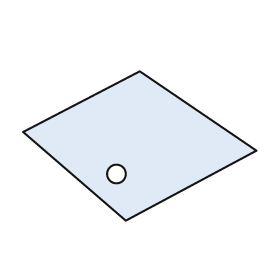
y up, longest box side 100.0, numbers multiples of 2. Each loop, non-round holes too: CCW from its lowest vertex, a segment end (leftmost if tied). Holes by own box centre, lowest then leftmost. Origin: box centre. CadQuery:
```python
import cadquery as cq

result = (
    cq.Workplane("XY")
    .moveTo(-6.0, -32.0)
    .lineTo(50.0, -2.0)
    .lineTo(0.0, 32.0)
    .lineTo(-50.0, 6.0)
    .close()
    .moveTo(-10.0, -12.0)
    .circle(4.0)
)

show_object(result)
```